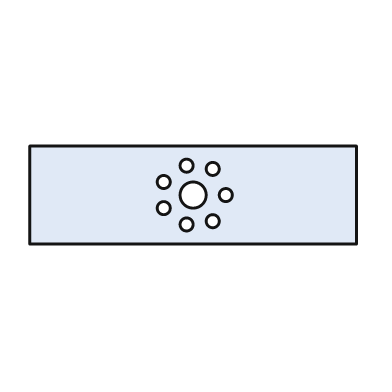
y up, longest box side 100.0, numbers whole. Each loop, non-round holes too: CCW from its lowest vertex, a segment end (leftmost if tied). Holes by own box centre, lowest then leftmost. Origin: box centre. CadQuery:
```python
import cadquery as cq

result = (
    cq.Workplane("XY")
    .moveTo(-50.0, -15.0)
    .lineTo(50.0, -15.0)
    .lineTo(50.0, 15.0)
    .lineTo(-50.0, 15.0)
    .close()
    .moveTo(-2.0, -9.0)
    .circle(2.0)
    .moveTo(6.0, -8.0)
    .circle(2.0)
    .moveTo(-9.0, -4.0)
    .circle(2.0)
    .moveTo(0.0, 0.0)
    .circle(4.0)
    .moveTo(10.0, 0.0)
    .circle(2.0)
    .moveTo(-9.0, 4.0)
    .circle(2.0)
    .moveTo(6.0, 8.0)
    .circle(2.0)
    .moveTo(-2.0, 9.0)
    .circle(2.0)
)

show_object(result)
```